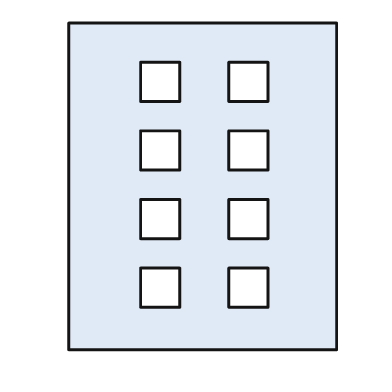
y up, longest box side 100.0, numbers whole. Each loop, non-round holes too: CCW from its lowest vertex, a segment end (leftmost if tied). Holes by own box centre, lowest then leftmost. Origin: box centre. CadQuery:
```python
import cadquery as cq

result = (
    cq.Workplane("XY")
    .moveTo(-41.0, -50.0)
    .lineTo(41.0, -50.0)
    .lineTo(41.0, 50.0)
    .lineTo(-41.0, 50.0)
    .close()
    .moveTo(-19.0, -37.0)
    .lineTo(-7.0, -37.0)
    .lineTo(-7.0, -25.0)
    .lineTo(-19.0, -25.0)
    .close()
    .moveTo(8.0, -37.0)
    .lineTo(20.0, -37.0)
    .lineTo(20.0, -25.0)
    .lineTo(8.0, -25.0)
    .close()
    .moveTo(-19.0, -16.0)
    .lineTo(-7.0, -16.0)
    .lineTo(-7.0, -4.0)
    .lineTo(-19.0, -4.0)
    .close()
    .moveTo(8.0, -16.0)
    .lineTo(20.0, -16.0)
    .lineTo(20.0, -4.0)
    .lineTo(8.0, -4.0)
    .close()
    .moveTo(-19.0, 5.0)
    .lineTo(-7.0, 5.0)
    .lineTo(-7.0, 17.0)
    .lineTo(-19.0, 17.0)
    .close()
    .moveTo(8.0, 5.0)
    .lineTo(20.0, 5.0)
    .lineTo(20.0, 17.0)
    .lineTo(8.0, 17.0)
    .close()
    .moveTo(-19.0, 26.0)
    .lineTo(-7.0, 26.0)
    .lineTo(-7.0, 38.0)
    .lineTo(-19.0, 38.0)
    .close()
    .moveTo(8.0, 26.0)
    .lineTo(20.0, 26.0)
    .lineTo(20.0, 38.0)
    .lineTo(8.0, 38.0)
    .close()
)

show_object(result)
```